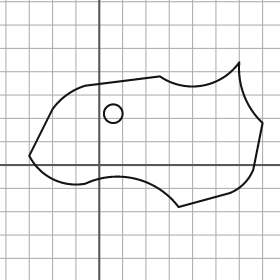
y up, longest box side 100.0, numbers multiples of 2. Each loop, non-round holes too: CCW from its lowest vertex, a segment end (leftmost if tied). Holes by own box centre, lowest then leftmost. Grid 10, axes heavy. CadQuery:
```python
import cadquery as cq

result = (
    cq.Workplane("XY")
    .moveTo(34.0, -18.0)
    .lineTo(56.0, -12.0)
    .threePointArc((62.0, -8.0), (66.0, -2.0))
    .lineTo(70.0, 18.0)
    .threePointArc((62.0, 30.0), (60.0, 44.0))
    .threePointArc((44.0, 34.0), (26.0, 38.0))
    .lineTo(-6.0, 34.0)
    .threePointArc((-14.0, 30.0), (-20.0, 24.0))
    .lineTo(-30.0, 4.0)
    .threePointArc((-20.0, -6.0), (-6.0, -8.0))
    .threePointArc((16.0, -6.0), (34.0, -18.0))
    .close()
    .moveTo(6.0, 22.0)
    .circle(4.0)
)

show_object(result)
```